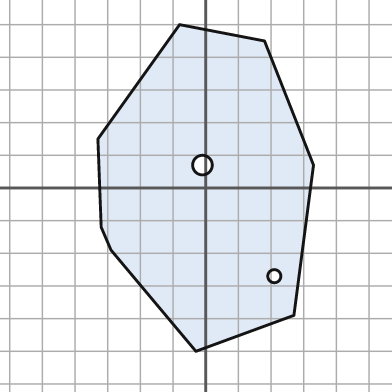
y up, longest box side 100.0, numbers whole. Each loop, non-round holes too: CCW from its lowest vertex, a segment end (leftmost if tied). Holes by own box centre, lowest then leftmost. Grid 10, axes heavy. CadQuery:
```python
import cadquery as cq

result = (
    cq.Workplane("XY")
    .moveTo(-3.0, -50.0)
    .lineTo(27.0, -39.0)
    .lineTo(33.0, 7.0)
    .lineTo(18.0, 45.0)
    .lineTo(-8.0, 50.0)
    .lineTo(-33.0, 15.0)
    .lineTo(-32.0, -12.0)
    .lineTo(-29.0, -19.0)
    .close()
    .moveTo(21.0, -27.0)
    .circle(2.0)
    .moveTo(-1.0, 7.0)
    .circle(3.0)
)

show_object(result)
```